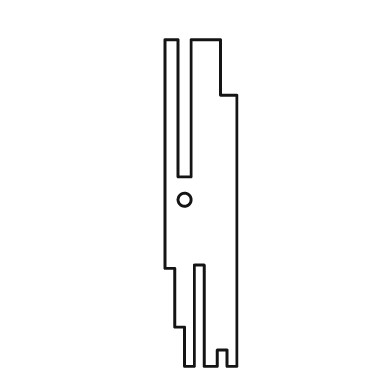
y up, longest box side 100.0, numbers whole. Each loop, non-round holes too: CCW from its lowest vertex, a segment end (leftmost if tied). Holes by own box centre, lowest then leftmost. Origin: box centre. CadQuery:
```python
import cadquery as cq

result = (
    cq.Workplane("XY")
    .moveTo(-5.0, -50.0)
    .lineTo(-2.0, -50.0)
    .lineTo(-2.0, -19.0)
    .lineTo(1.0, -19.0)
    .lineTo(1.0, -50.0)
    .lineTo(5.0, -50.0)
    .lineTo(5.0, -45.0)
    .lineTo(8.0, -45.0)
    .lineTo(8.0, -50.0)
    .lineTo(11.0, -50.0)
    .lineTo(11.0, 33.0)
    .lineTo(6.0, 33.0)
    .lineTo(6.0, 50.0)
    .lineTo(-3.0, 50.0)
    .lineTo(-3.0, 8.0)
    .lineTo(-7.0, 8.0)
    .lineTo(-7.0, 50.0)
    .lineTo(-11.0, 50.0)
    .lineTo(-11.0, -20.0)
    .lineTo(-8.0, -20.0)
    .lineTo(-8.0, -38.0)
    .lineTo(-5.0, -38.0)
    .close()
    .moveTo(-5.0, 1.0)
    .circle(2.0)
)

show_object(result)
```